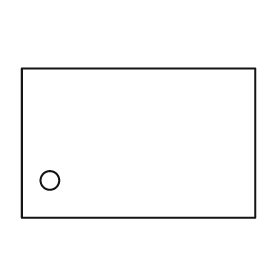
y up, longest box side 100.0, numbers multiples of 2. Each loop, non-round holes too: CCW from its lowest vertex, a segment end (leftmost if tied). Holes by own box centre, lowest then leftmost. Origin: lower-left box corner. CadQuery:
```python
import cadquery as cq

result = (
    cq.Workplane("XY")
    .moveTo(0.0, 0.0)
    .lineTo(100.0, 0.0)
    .lineTo(100.0, 64.0)
    .lineTo(0.0, 64.0)
    .close()
    .moveTo(12.0, 16.0)
    .circle(4.0)
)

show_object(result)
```